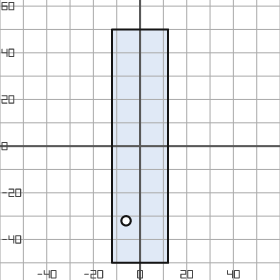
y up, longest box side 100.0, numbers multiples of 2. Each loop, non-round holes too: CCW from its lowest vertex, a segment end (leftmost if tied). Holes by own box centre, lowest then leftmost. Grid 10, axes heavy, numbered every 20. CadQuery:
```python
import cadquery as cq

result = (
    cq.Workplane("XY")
    .moveTo(-12.0, -50.0)
    .lineTo(12.0, -50.0)
    .lineTo(12.0, 50.0)
    .lineTo(-12.0, 50.0)
    .close()
    .moveTo(-6.0, -32.0)
    .circle(2.0)
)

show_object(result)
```